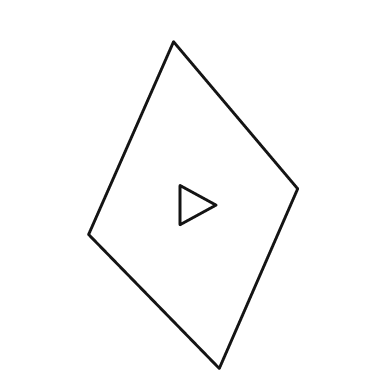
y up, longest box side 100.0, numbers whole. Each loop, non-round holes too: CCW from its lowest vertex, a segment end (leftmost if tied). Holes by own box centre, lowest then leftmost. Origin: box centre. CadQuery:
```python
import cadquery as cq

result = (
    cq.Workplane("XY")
    .moveTo(8.0, -50.0)
    .lineTo(32.0, 5.0)
    .lineTo(-6.0, 50.0)
    .lineTo(-32.0, -9.0)
    .close()
    .moveTo(-4.0, -6.0)
    .lineTo(7.0, 0.0)
    .lineTo(-4.0, 6.0)
    .close()
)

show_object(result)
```